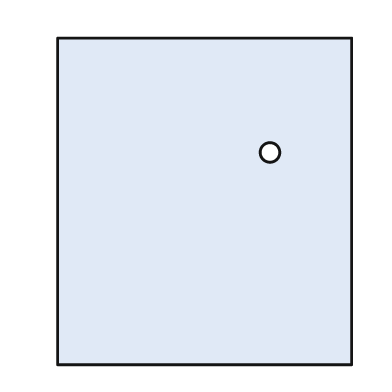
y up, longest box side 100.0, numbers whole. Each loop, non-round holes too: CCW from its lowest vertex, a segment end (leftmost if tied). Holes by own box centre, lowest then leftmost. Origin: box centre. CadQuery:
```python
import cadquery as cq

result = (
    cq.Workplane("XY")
    .moveTo(-45.0, -50.0)
    .lineTo(45.0, -50.0)
    .lineTo(45.0, 50.0)
    .lineTo(-45.0, 50.0)
    .close()
    .moveTo(20.0, 15.0)
    .circle(3.0)
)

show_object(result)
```